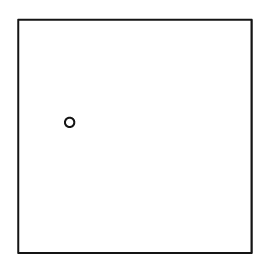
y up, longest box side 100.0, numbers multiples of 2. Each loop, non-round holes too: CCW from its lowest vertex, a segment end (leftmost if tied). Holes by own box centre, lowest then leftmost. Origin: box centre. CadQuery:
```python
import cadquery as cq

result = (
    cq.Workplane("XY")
    .moveTo(-50.0, -50.0)
    .lineTo(50.0, -50.0)
    .lineTo(50.0, 50.0)
    .lineTo(-50.0, 50.0)
    .close()
    .moveTo(-28.0, 6.0)
    .circle(2.0)
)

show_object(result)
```